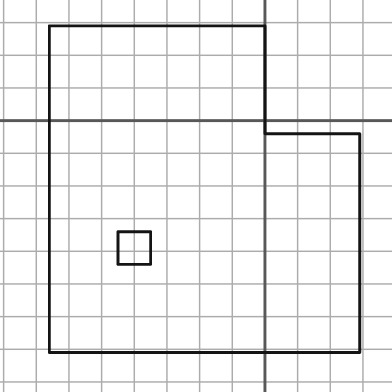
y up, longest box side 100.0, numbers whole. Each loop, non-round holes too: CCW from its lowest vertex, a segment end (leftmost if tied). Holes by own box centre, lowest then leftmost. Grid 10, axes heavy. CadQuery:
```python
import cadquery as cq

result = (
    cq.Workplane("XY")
    .moveTo(-66.0, -71.0)
    .lineTo(29.0, -71.0)
    .lineTo(29.0, -4.0)
    .lineTo(0.0, -4.0)
    .lineTo(0.0, 29.0)
    .lineTo(-66.0, 29.0)
    .close()
    .moveTo(-45.0, -44.0)
    .lineTo(-35.0, -44.0)
    .lineTo(-35.0, -34.0)
    .lineTo(-45.0, -34.0)
    .close()
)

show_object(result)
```